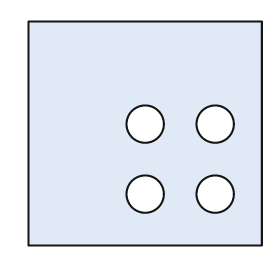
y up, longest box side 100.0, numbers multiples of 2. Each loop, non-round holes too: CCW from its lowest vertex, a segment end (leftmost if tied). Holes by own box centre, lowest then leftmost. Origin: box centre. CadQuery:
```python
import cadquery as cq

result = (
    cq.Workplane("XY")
    .moveTo(-50.0, -48.0)
    .lineTo(50.0, -48.0)
    .lineTo(50.0, 48.0)
    .lineTo(-50.0, 48.0)
    .close()
    .moveTo(0.0, -26.0)
    .circle(8.0)
    .moveTo(30.0, -26.0)
    .circle(8.0)
    .moveTo(0.0, 4.0)
    .circle(8.0)
    .moveTo(30.0, 4.0)
    .circle(8.0)
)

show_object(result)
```